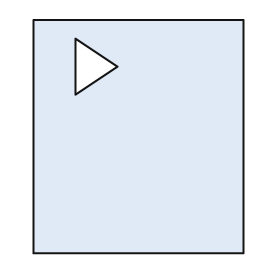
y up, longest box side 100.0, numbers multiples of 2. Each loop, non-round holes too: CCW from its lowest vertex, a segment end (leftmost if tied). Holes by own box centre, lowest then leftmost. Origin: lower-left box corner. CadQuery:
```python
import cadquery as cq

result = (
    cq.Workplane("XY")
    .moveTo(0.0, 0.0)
    .lineTo(90.0, 0.0)
    .lineTo(90.0, 100.0)
    .lineTo(0.0, 100.0)
    .close()
    .moveTo(18.0, 68.0)
    .lineTo(36.0, 80.0)
    .lineTo(18.0, 92.0)
    .close()
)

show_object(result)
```